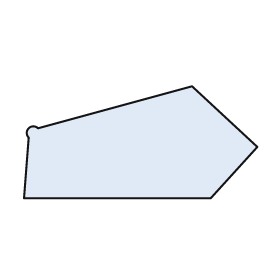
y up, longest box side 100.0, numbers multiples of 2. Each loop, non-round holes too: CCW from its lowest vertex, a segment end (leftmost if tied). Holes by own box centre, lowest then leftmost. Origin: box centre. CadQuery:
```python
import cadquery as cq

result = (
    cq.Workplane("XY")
    .moveTo(-50.0, -24.0)
    .lineTo(30.0, -24.0)
    .lineTo(50.0, -2.0)
    .lineTo(22.0, 24.0)
    .lineTo(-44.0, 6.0)
    .threePointArc((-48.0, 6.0), (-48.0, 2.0))
    .close()
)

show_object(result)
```